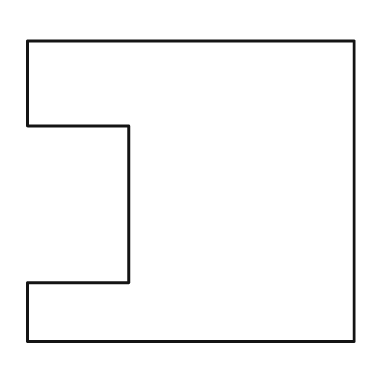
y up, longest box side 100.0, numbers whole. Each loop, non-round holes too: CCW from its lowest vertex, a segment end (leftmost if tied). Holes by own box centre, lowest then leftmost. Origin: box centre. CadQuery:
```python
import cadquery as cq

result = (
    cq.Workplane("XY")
    .moveTo(-50.0, -46.0)
    .lineTo(50.0, -46.0)
    .lineTo(50.0, 46.0)
    .lineTo(-50.0, 46.0)
    .lineTo(-50.0, 20.0)
    .lineTo(-19.0, 20.0)
    .lineTo(-19.0, -28.0)
    .lineTo(-50.0, -28.0)
    .close()
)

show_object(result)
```